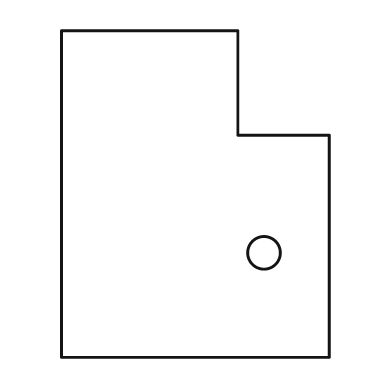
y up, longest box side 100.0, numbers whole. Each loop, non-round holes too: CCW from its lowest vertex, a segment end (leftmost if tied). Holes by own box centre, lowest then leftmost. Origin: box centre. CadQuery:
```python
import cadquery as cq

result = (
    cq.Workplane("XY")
    .moveTo(-41.0, -50.0)
    .lineTo(41.0, -50.0)
    .lineTo(41.0, 18.0)
    .lineTo(13.0, 18.0)
    .lineTo(13.0, 50.0)
    .lineTo(-41.0, 50.0)
    .close()
    .moveTo(21.0, -18.0)
    .circle(5.0)
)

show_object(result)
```